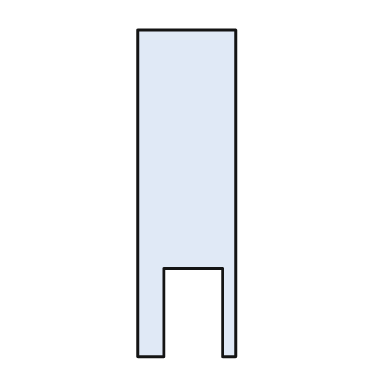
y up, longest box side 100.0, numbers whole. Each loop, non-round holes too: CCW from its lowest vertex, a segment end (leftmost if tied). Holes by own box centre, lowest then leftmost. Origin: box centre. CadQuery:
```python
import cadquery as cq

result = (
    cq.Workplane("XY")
    .moveTo(-15.0, -50.0)
    .lineTo(-7.0, -50.0)
    .lineTo(-7.0, -23.0)
    .lineTo(11.0, -23.0)
    .lineTo(11.0, -50.0)
    .lineTo(15.0, -50.0)
    .lineTo(15.0, 50.0)
    .lineTo(-15.0, 50.0)
    .close()
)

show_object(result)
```